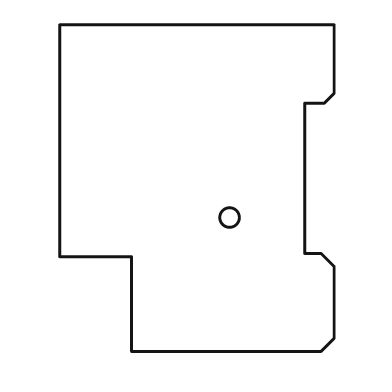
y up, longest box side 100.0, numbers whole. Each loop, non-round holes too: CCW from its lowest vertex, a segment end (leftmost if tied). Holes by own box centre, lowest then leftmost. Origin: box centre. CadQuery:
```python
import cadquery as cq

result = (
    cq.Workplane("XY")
    .moveTo(-20.0, -50.0)
    .lineTo(38.0, -50.0)
    .lineTo(42.0, -46.0)
    .lineTo(42.0, -24.0)
    .lineTo(38.0, -20.0)
    .lineTo(33.0, -20.0)
    .lineTo(33.0, 26.0)
    .lineTo(39.0, 26.0)
    .lineTo(42.0, 29.0)
    .lineTo(42.0, 50.0)
    .lineTo(-42.0, 50.0)
    .lineTo(-42.0, -21.0)
    .lineTo(-20.0, -21.0)
    .close()
    .moveTo(10.0, -9.0)
    .circle(3.0)
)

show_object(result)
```